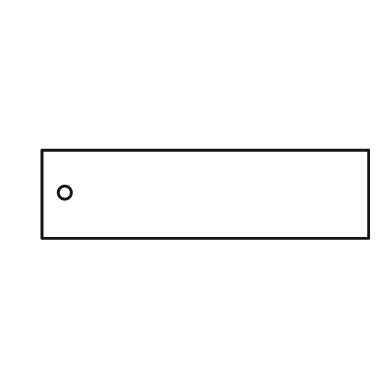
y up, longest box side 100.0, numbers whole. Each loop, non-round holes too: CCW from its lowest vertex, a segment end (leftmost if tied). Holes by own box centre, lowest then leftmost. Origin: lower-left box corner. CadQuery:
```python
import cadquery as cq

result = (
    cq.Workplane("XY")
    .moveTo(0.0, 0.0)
    .lineTo(100.0, 0.0)
    .lineTo(100.0, 27.0)
    .lineTo(0.0, 27.0)
    .close()
    .moveTo(7.0, 14.0)
    .circle(2.0)
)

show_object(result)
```